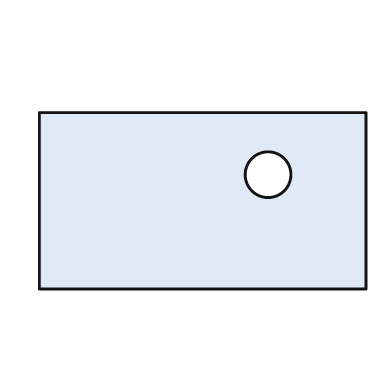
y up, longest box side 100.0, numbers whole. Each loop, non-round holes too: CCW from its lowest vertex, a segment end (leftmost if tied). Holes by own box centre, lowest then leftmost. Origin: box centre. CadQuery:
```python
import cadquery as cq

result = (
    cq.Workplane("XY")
    .moveTo(-50.0, -27.0)
    .lineTo(50.0, -27.0)
    .lineTo(50.0, 27.0)
    .lineTo(-50.0, 27.0)
    .close()
    .moveTo(20.0, 8.0)
    .circle(7.0)
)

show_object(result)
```